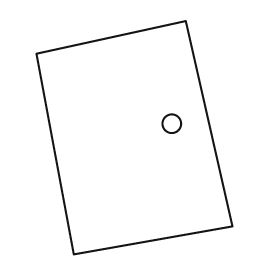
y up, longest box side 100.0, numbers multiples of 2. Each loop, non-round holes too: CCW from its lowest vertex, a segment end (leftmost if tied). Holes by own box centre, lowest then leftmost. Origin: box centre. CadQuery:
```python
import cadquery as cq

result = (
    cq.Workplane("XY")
    .moveTo(-26.0, -50.0)
    .lineTo(42.0, -38.0)
    .lineTo(22.0, 50.0)
    .lineTo(-42.0, 36.0)
    .close()
    .moveTo(16.0, 6.0)
    .circle(4.0)
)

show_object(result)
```